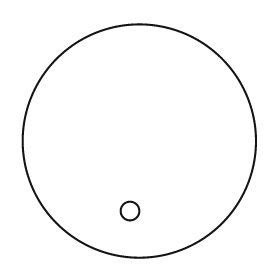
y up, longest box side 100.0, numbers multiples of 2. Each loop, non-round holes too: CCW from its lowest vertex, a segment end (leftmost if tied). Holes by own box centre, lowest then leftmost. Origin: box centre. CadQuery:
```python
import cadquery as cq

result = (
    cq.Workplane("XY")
    .moveTo(0.0, 0.0)
    .circle(50.0)
    .moveTo(-4.0, -30.0)
    .circle(4.0)
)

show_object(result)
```